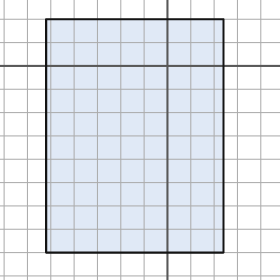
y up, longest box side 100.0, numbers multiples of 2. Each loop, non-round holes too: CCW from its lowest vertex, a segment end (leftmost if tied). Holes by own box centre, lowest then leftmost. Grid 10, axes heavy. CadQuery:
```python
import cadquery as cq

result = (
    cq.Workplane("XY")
    .moveTo(-52.0, -80.0)
    .lineTo(24.0, -80.0)
    .lineTo(24.0, 20.0)
    .lineTo(-52.0, 20.0)
    .close()
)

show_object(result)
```